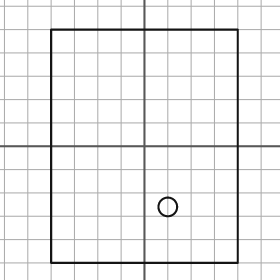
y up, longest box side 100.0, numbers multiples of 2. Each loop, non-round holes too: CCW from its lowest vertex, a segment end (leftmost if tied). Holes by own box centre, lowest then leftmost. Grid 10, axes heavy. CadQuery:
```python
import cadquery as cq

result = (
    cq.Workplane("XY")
    .moveTo(-40.0, -50.0)
    .lineTo(40.0, -50.0)
    .lineTo(40.0, 50.0)
    .lineTo(-40.0, 50.0)
    .close()
    .moveTo(10.0, -26.0)
    .circle(4.0)
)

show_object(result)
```